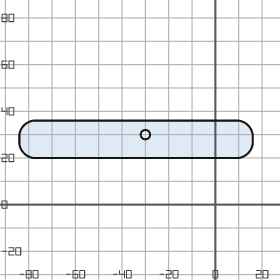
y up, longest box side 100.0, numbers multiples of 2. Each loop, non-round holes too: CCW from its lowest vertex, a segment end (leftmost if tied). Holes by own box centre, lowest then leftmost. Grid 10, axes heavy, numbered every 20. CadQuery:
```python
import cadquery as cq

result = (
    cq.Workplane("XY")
    .moveTo(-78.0, 20.0)
    .lineTo(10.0, 20.0)
    .threePointArc((14.0, 22.0), (16.0, 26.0))
    .lineTo(16.0, 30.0)
    .threePointArc((14.0, 34.0), (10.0, 36.0))
    .lineTo(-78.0, 36.0)
    .threePointArc((-82.0, 34.0), (-84.0, 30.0))
    .lineTo(-84.0, 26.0)
    .threePointArc((-82.0, 22.0), (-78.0, 20.0))
    .close()
    .moveTo(-30.0, 30.0)
    .circle(2.0)
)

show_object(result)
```